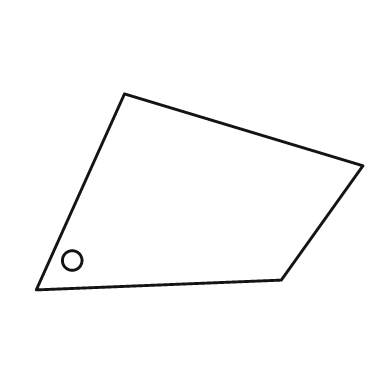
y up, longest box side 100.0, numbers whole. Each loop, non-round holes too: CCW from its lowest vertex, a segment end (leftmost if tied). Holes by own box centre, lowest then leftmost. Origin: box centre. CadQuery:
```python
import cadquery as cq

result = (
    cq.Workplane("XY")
    .moveTo(-50.0, -30.0)
    .lineTo(25.0, -27.0)
    .lineTo(50.0, 8.0)
    .lineTo(-23.0, 30.0)
    .close()
    .moveTo(-39.0, -21.0)
    .circle(3.0)
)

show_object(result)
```